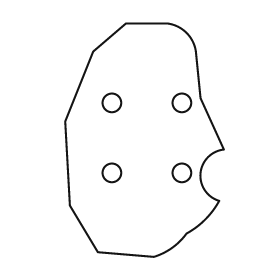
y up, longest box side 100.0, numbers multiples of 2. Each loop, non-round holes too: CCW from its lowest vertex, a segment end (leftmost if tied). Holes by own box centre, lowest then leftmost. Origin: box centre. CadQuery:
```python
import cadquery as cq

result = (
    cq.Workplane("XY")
    .moveTo(4.0, -50.0)
    .threePointArc((12.0, -46.0), (18.0, -40.0))
    .threePointArc((26.0, -34.0), (32.0, -26.0))
    .threePointArc((24.0, -14.0), (34.0, -4.0))
    .lineTo(24.0, 18.0)
    .lineTo(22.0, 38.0)
    .threePointArc((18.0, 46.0), (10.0, 50.0))
    .lineTo(-8.0, 50.0)
    .lineTo(-22.0, 38.0)
    .lineTo(-34.0, 8.0)
    .lineTo(-32.0, -28.0)
    .lineTo(-20.0, -48.0)
    .close()
    .moveTo(-14.0, -14.0)
    .circle(4.0)
    .moveTo(16.0, -14.0)
    .circle(4.0)
    .moveTo(-14.0, 16.0)
    .circle(4.0)
    .moveTo(16.0, 16.0)
    .circle(4.0)
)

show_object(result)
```